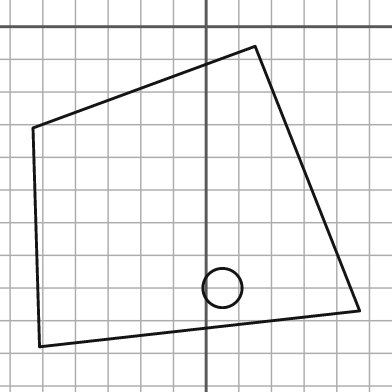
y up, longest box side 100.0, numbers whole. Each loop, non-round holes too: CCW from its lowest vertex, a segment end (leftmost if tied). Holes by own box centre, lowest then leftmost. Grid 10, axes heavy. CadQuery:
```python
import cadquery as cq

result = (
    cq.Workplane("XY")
    .moveTo(-51.0, -98.0)
    .lineTo(47.0, -87.0)
    .lineTo(15.0, -6.0)
    .lineTo(-53.0, -31.0)
    .close()
    .moveTo(5.0, -80.0)
    .circle(6.0)
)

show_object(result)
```